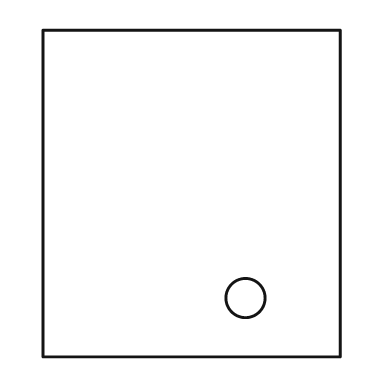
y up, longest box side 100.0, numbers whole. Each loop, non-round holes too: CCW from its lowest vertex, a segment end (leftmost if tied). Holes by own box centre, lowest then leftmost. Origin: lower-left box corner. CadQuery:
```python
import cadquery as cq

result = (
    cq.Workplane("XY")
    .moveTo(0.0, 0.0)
    .lineTo(91.0, 0.0)
    .lineTo(91.0, 100.0)
    .lineTo(0.0, 100.0)
    .close()
    .moveTo(62.0, 18.0)
    .circle(6.0)
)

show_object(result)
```